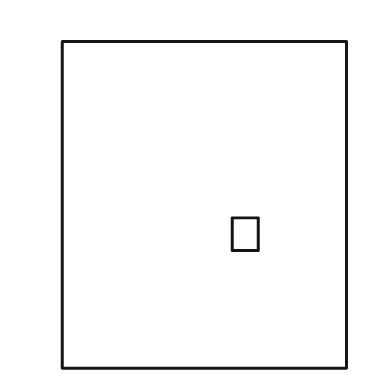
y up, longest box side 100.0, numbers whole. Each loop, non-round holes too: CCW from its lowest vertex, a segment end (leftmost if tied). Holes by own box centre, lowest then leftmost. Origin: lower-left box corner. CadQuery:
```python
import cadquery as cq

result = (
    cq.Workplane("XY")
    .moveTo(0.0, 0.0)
    .lineTo(87.0, 0.0)
    .lineTo(87.0, 100.0)
    .lineTo(0.0, 100.0)
    .close()
    .moveTo(52.0, 36.0)
    .lineTo(60.0, 36.0)
    .lineTo(60.0, 46.0)
    .lineTo(52.0, 46.0)
    .close()
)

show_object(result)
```